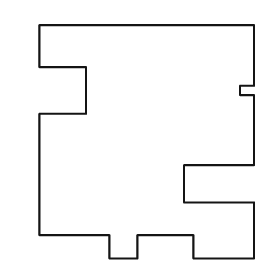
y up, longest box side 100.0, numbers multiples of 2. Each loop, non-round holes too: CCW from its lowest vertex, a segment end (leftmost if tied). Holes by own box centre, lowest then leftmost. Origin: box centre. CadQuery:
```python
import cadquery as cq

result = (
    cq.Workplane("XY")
    .moveTo(-16.0, -50.0)
    .lineTo(-4.0, -50.0)
    .lineTo(-4.0, -40.0)
    .lineTo(20.0, -40.0)
    .lineTo(20.0, -50.0)
    .lineTo(46.0, -50.0)
    .lineTo(46.0, -26.0)
    .lineTo(16.0, -26.0)
    .lineTo(16.0, -10.0)
    .lineTo(46.0, -10.0)
    .lineTo(46.0, 20.0)
    .lineTo(40.0, 20.0)
    .lineTo(40.0, 24.0)
    .lineTo(46.0, 24.0)
    .lineTo(46.0, 50.0)
    .lineTo(-46.0, 50.0)
    .lineTo(-46.0, 32.0)
    .lineTo(-26.0, 32.0)
    .lineTo(-26.0, 12.0)
    .lineTo(-46.0, 12.0)
    .lineTo(-46.0, -40.0)
    .lineTo(-16.0, -40.0)
    .close()
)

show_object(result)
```